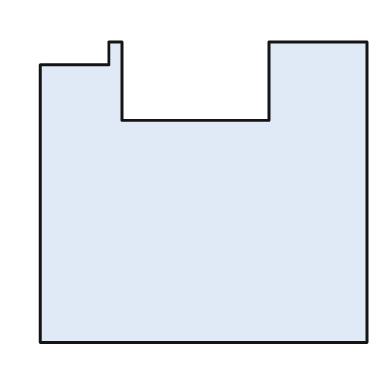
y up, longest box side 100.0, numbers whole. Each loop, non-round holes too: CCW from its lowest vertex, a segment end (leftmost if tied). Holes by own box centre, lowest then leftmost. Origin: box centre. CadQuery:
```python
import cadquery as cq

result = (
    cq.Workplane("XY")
    .moveTo(-50.0, -46.0)
    .lineTo(50.0, -46.0)
    .lineTo(50.0, 46.0)
    .lineTo(20.0, 46.0)
    .lineTo(20.0, 22.0)
    .lineTo(-25.0, 22.0)
    .lineTo(-25.0, 46.0)
    .lineTo(-29.0, 46.0)
    .lineTo(-29.0, 39.0)
    .lineTo(-50.0, 39.0)
    .close()
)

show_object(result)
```